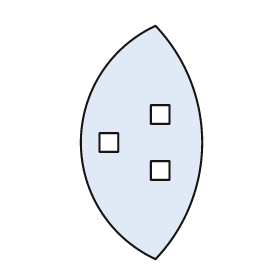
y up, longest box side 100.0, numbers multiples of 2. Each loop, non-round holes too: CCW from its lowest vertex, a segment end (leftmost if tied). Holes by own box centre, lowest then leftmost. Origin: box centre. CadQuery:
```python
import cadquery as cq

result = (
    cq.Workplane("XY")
    .moveTo(6.0, -50.0)
    .threePointArc((26.0, 0.0), (6.0, 50.0))
    .threePointArc((-26.0, 0.0), (6.0, -50.0))
    .close()
    .moveTo(4.0, -16.0)
    .lineTo(12.0, -16.0)
    .lineTo(12.0, -8.0)
    .lineTo(4.0, -8.0)
    .close()
    .moveTo(-18.0, -4.0)
    .lineTo(-10.0, -4.0)
    .lineTo(-10.0, 4.0)
    .lineTo(-18.0, 4.0)
    .close()
    .moveTo(4.0, 8.0)
    .lineTo(12.0, 8.0)
    .lineTo(12.0, 16.0)
    .lineTo(4.0, 16.0)
    .close()
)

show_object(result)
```